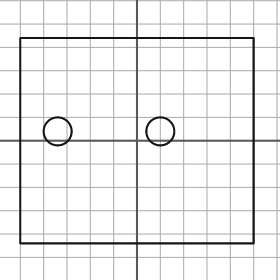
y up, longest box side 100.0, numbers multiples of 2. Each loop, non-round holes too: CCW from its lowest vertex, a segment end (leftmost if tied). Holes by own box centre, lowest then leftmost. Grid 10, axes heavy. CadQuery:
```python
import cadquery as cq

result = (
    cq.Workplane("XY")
    .moveTo(-50.0, -44.0)
    .lineTo(50.0, -44.0)
    .lineTo(50.0, 44.0)
    .lineTo(-50.0, 44.0)
    .close()
    .moveTo(-34.0, 4.0)
    .circle(6.0)
    .moveTo(10.0, 4.0)
    .circle(6.0)
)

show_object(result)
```